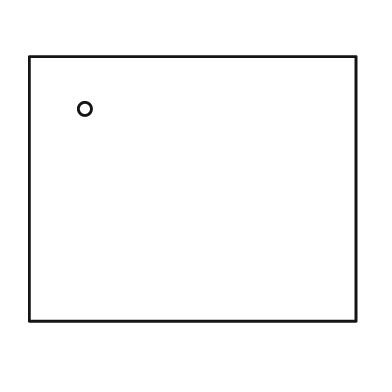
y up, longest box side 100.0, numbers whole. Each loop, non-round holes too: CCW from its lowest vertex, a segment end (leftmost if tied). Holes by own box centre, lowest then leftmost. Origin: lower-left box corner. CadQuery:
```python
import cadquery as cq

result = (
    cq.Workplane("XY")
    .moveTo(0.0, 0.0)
    .lineTo(100.0, 0.0)
    .lineTo(100.0, 81.0)
    .lineTo(0.0, 81.0)
    .close()
    .moveTo(17.0, 65.0)
    .circle(2.0)
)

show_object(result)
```